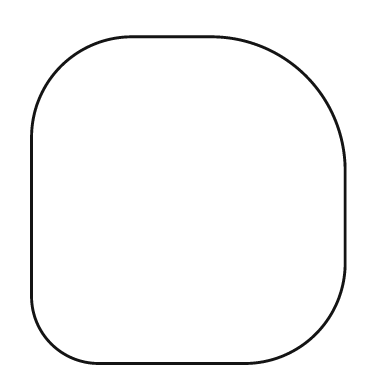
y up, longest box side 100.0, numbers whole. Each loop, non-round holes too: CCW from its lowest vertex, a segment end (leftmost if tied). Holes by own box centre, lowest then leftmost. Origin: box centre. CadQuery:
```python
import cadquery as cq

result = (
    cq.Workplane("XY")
    .moveTo(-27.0, -50.0)
    .lineTo(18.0, -50.0)
    .threePointArc((39.0, -41.0), (48.0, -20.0))
    .lineTo(48.0, 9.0)
    .threePointArc((36.0, 38.0), (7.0, 50.0))
    .lineTo(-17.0, 50.0)
    .threePointArc((-39.0, 41.0), (-48.0, 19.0))
    .lineTo(-48.0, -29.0)
    .threePointArc((-42.0, -44.0), (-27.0, -50.0))
    .close()
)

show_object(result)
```